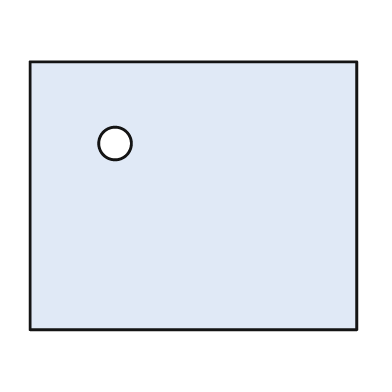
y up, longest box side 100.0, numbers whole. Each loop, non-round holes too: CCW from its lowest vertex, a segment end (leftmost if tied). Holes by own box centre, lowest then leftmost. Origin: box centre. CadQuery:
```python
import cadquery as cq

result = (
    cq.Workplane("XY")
    .moveTo(-50.0, -41.0)
    .lineTo(50.0, -41.0)
    .lineTo(50.0, 41.0)
    .lineTo(-50.0, 41.0)
    .close()
    .moveTo(-24.0, 16.0)
    .circle(5.0)
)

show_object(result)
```